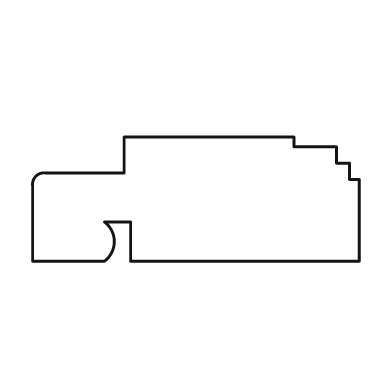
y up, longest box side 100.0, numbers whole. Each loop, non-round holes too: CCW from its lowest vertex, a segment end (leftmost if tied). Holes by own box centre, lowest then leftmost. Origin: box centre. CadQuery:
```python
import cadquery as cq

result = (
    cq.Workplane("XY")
    .moveTo(-50.0, -19.0)
    .lineTo(-28.0, -19.0)
    .threePointArc((-25.0, -13.0), (-28.0, -7.0))
    .lineTo(-20.0, -7.0)
    .lineTo(-20.0, -19.0)
    .lineTo(50.0, -19.0)
    .lineTo(50.0, 6.0)
    .lineTo(47.0, 6.0)
    .lineTo(47.0, 11.0)
    .lineTo(43.0, 11.0)
    .lineTo(43.0, 16.0)
    .lineTo(30.0, 16.0)
    .lineTo(30.0, 19.0)
    .lineTo(-22.0, 19.0)
    .lineTo(-22.0, 8.0)
    .lineTo(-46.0, 8.0)
    .threePointArc((-49.0, 7.0), (-50.0, 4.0))
    .close()
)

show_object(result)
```